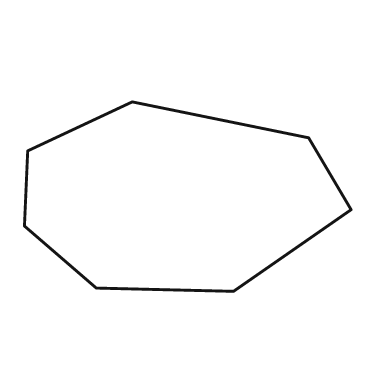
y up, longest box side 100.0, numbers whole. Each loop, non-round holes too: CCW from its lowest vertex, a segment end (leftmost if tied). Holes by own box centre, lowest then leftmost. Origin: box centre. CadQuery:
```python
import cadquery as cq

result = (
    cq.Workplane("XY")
    .moveTo(14.0, -29.0)
    .lineTo(50.0, -4.0)
    .lineTo(37.0, 18.0)
    .lineTo(-17.0, 29.0)
    .lineTo(-49.0, 14.0)
    .lineTo(-50.0, -9.0)
    .lineTo(-28.0, -28.0)
    .close()
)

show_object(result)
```